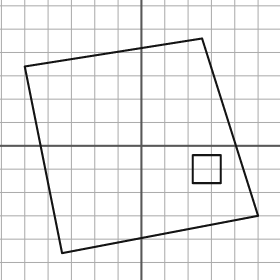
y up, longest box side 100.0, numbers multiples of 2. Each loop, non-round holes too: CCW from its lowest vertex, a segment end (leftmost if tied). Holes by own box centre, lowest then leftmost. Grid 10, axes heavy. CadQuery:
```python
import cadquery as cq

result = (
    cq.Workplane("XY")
    .moveTo(-34.0, -46.0)
    .lineTo(50.0, -30.0)
    .lineTo(26.0, 46.0)
    .lineTo(-50.0, 34.0)
    .close()
    .moveTo(22.0, -16.0)
    .lineTo(34.0, -16.0)
    .lineTo(34.0, -4.0)
    .lineTo(22.0, -4.0)
    .close()
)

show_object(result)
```